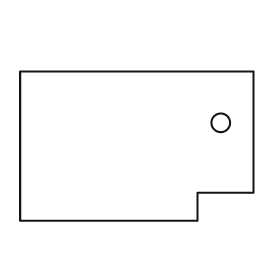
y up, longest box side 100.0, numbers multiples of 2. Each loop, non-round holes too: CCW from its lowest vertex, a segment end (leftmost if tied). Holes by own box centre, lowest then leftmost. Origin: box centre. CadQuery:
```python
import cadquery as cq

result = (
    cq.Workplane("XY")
    .moveTo(-50.0, -32.0)
    .lineTo(26.0, -32.0)
    .lineTo(26.0, -20.0)
    .lineTo(50.0, -20.0)
    .lineTo(50.0, 32.0)
    .lineTo(-50.0, 32.0)
    .close()
    .moveTo(36.0, 10.0)
    .circle(4.0)
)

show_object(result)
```